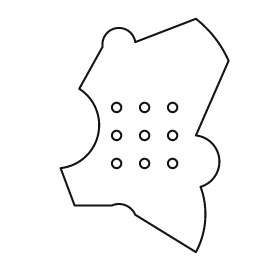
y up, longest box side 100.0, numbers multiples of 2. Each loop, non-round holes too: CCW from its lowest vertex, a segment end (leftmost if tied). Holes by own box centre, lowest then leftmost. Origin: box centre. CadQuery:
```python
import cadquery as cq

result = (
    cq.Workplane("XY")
    .moveTo(22.0, -50.0)
    .threePointArc((26.0, -36.0), (24.0, -22.0))
    .threePointArc((32.0, -10.0), (22.0, 0.0))
    .lineTo(36.0, 32.0)
    .threePointArc((30.0, 42.0), (22.0, 50.0))
    .lineTo(-4.0, 40.0)
    .threePointArc((-12.0, 46.0), (-18.0, 38.0))
    .lineTo(-28.0, 20.0)
    .threePointArc((-20.0, 0.0), (-36.0, -14.0))
    .lineTo(-30.0, -30.0)
    .lineTo(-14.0, -30.0)
    .threePointArc((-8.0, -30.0), (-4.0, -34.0))
    .close()
    .moveTo(-12.0, -12.0)
    .circle(2.0)
    .moveTo(0.0, -12.0)
    .circle(2.0)
    .moveTo(12.0, -12.0)
    .circle(2.0)
    .moveTo(-12.0, 0.0)
    .circle(2.0)
    .moveTo(0.0, 0.0)
    .circle(2.0)
    .moveTo(12.0, 0.0)
    .circle(2.0)
    .moveTo(-12.0, 12.0)
    .circle(2.0)
    .moveTo(0.0, 12.0)
    .circle(2.0)
    .moveTo(12.0, 12.0)
    .circle(2.0)
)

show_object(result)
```